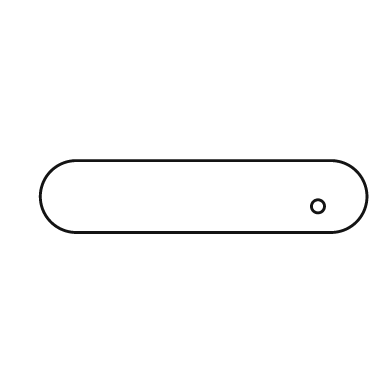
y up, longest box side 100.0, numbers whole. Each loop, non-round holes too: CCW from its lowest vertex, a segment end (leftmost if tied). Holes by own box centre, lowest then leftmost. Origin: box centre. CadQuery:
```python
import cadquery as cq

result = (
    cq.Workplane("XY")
    .moveTo(-39.0, -11.0)
    .lineTo(39.0, -11.0)
    .threePointArc((50.0, 0.0), (39.0, 11.0))
    .lineTo(-39.0, 11.0)
    .threePointArc((-50.0, 0.0), (-39.0, -11.0))
    .close()
    .moveTo(35.0, -3.0)
    .circle(2.0)
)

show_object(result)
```